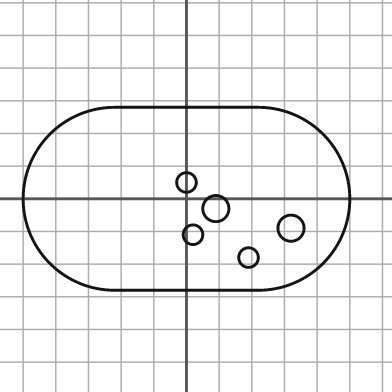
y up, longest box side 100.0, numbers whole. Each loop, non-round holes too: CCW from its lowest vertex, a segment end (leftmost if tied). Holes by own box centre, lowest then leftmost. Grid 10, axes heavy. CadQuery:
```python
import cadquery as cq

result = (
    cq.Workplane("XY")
    .moveTo(-22.0, -28.0)
    .lineTo(22.0, -28.0)
    .threePointArc((50.0, 0.0), (22.0, 28.0))
    .lineTo(-22.0, 28.0)
    .threePointArc((-50.0, 0.0), (-22.0, -28.0))
    .close()
    .moveTo(19.0, -18.0)
    .circle(3.0)
    .moveTo(2.0, -11.0)
    .circle(3.0)
    .moveTo(32.0, -9.0)
    .circle(4.0)
    .moveTo(9.0, -3.0)
    .circle(4.0)
    .moveTo(0.0, 5.0)
    .circle(3.0)
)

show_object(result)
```